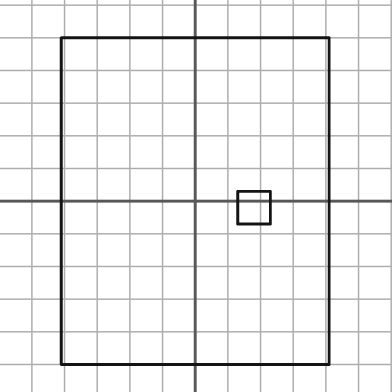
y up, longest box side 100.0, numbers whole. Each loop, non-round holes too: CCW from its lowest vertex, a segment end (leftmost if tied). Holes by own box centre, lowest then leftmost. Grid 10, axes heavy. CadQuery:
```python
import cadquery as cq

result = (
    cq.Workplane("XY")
    .moveTo(-41.0, -50.0)
    .lineTo(41.0, -50.0)
    .lineTo(41.0, 50.0)
    .lineTo(-41.0, 50.0)
    .close()
    .moveTo(13.0, -7.0)
    .lineTo(23.0, -7.0)
    .lineTo(23.0, 3.0)
    .lineTo(13.0, 3.0)
    .close()
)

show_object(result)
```